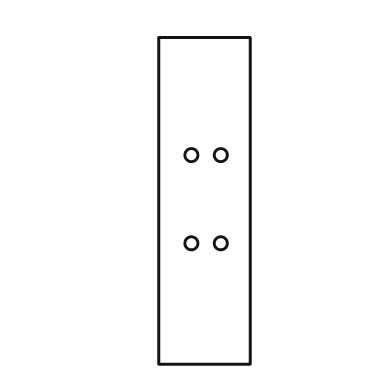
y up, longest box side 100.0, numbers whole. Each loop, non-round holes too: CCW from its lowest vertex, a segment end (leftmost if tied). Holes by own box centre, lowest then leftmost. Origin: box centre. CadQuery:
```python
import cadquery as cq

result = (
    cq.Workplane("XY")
    .moveTo(-14.0, -50.0)
    .lineTo(14.0, -50.0)
    .lineTo(14.0, 50.0)
    .lineTo(-14.0, 50.0)
    .close()
    .moveTo(-4.0, -13.0)
    .circle(2.0)
    .moveTo(5.0, -13.0)
    .circle(2.0)
    .moveTo(-4.0, 14.0)
    .circle(2.0)
    .moveTo(5.0, 14.0)
    .circle(2.0)
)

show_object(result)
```